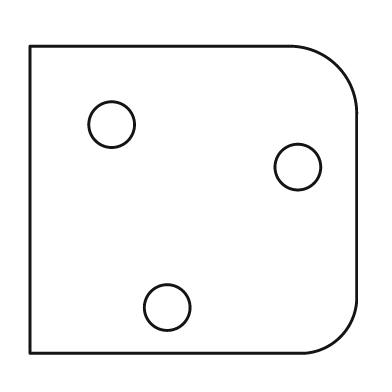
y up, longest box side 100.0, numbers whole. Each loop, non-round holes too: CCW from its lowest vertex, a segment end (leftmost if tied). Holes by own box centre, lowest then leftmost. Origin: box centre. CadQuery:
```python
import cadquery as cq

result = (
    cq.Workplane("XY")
    .moveTo(-50.0, -47.0)
    .lineTo(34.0, -47.0)
    .threePointArc((45.0, -42.0), (50.0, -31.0))
    .lineTo(50.0, 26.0)
    .threePointArc((44.0, 41.0), (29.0, 47.0))
    .lineTo(-50.0, 47.0)
    .close()
    .moveTo(-8.0, -33.0)
    .circle(7.0)
    .moveTo(32.0, 10.0)
    .circle(7.0)
    .moveTo(-25.0, 23.0)
    .circle(7.0)
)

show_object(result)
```